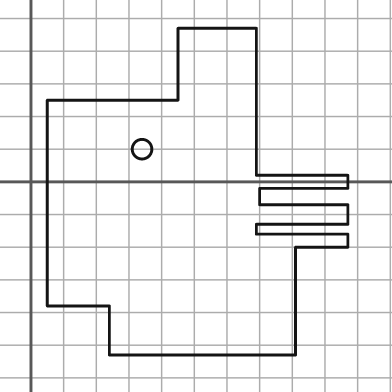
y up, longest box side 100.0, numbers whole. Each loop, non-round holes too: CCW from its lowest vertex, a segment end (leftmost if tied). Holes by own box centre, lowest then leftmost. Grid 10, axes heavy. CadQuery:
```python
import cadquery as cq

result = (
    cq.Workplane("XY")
    .moveTo(24.0, -53.0)
    .lineTo(81.0, -53.0)
    .lineTo(81.0, -20.0)
    .lineTo(97.0, -20.0)
    .lineTo(97.0, -16.0)
    .lineTo(69.0, -16.0)
    .lineTo(69.0, -13.0)
    .lineTo(97.0, -13.0)
    .lineTo(97.0, -7.0)
    .lineTo(70.0, -7.0)
    .lineTo(70.0, -2.0)
    .lineTo(97.0, -2.0)
    .lineTo(97.0, 2.0)
    .lineTo(69.0, 2.0)
    .lineTo(69.0, 47.0)
    .lineTo(45.0, 47.0)
    .lineTo(45.0, 25.0)
    .lineTo(5.0, 25.0)
    .lineTo(5.0, -38.0)
    .lineTo(24.0, -38.0)
    .close()
    .moveTo(34.0, 10.0)
    .circle(3.0)
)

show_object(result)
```